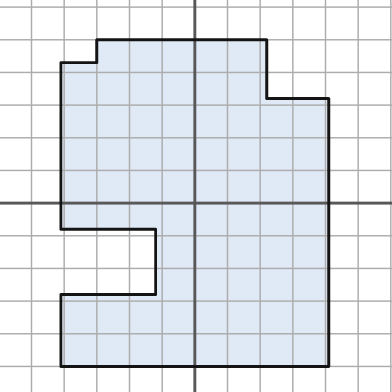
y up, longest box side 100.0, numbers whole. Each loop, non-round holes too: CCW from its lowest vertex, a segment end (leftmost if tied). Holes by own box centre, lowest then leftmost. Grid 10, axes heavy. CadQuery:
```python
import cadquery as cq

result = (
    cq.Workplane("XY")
    .moveTo(-41.0, -50.0)
    .lineTo(41.0, -50.0)
    .lineTo(41.0, 32.0)
    .lineTo(22.0, 32.0)
    .lineTo(22.0, 50.0)
    .lineTo(-30.0, 50.0)
    .lineTo(-30.0, 43.0)
    .lineTo(-41.0, 43.0)
    .lineTo(-41.0, -8.0)
    .lineTo(-12.0, -8.0)
    .lineTo(-12.0, -28.0)
    .lineTo(-41.0, -28.0)
    .close()
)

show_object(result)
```